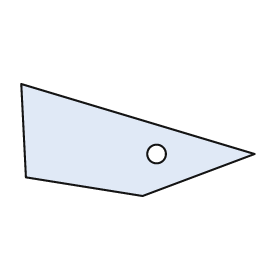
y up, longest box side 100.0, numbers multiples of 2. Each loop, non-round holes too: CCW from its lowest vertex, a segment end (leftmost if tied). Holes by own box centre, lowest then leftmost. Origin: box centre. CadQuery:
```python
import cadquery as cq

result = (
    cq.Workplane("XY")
    .moveTo(2.0, -24.0)
    .lineTo(50.0, -6.0)
    .lineTo(-50.0, 24.0)
    .lineTo(-48.0, -16.0)
    .close()
    .moveTo(8.0, -6.0)
    .circle(4.0)
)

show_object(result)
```